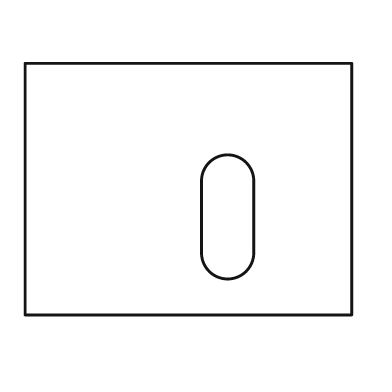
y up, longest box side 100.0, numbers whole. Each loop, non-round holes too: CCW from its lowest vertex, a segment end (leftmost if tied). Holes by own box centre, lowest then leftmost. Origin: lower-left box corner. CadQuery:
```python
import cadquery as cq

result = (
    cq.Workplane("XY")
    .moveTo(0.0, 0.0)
    .lineTo(100.0, 0.0)
    .lineTo(100.0, 77.0)
    .lineTo(0.0, 77.0)
    .close()
    .moveTo(54.0, 19.0)
    .threePointArc((62.0, 11.0), (70.0, 19.0))
    .lineTo(70.0, 41.0)
    .threePointArc((62.0, 49.0), (54.0, 41.0))
    .close()
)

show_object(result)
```